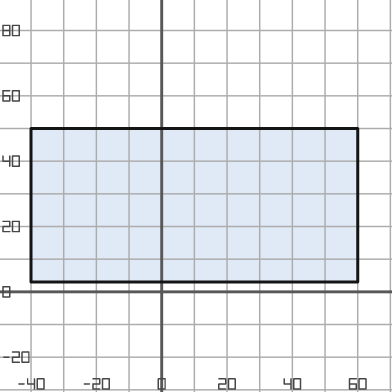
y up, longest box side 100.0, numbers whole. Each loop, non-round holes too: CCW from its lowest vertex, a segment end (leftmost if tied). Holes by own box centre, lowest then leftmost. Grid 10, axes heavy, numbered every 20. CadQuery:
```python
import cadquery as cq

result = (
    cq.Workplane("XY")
    .moveTo(-40.0, 3.0)
    .lineTo(60.0, 3.0)
    .lineTo(60.0, 50.0)
    .lineTo(-40.0, 50.0)
    .close()
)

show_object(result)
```